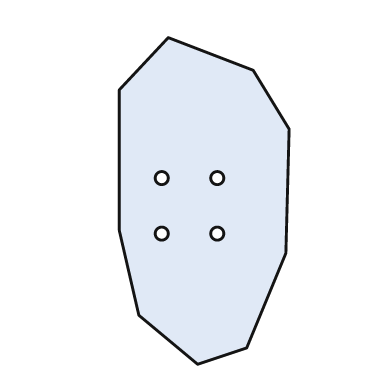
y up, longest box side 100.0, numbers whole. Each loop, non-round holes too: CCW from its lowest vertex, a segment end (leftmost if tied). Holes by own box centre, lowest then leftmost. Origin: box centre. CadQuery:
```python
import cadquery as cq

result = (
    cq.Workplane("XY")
    .moveTo(-2.0, -50.0)
    .lineTo(13.0, -45.0)
    .lineTo(25.0, -16.0)
    .lineTo(26.0, 22.0)
    .lineTo(15.0, 40.0)
    .lineTo(-11.0, 50.0)
    .lineTo(-26.0, 34.0)
    .lineTo(-26.0, -9.0)
    .lineTo(-20.0, -35.0)
    .close()
    .moveTo(-13.0, -10.0)
    .circle(2.0)
    .moveTo(4.0, -10.0)
    .circle(2.0)
    .moveTo(-13.0, 7.0)
    .circle(2.0)
    .moveTo(4.0, 7.0)
    .circle(2.0)
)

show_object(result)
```